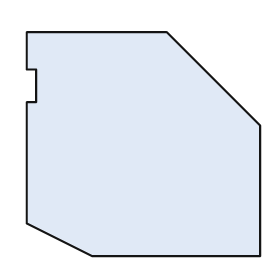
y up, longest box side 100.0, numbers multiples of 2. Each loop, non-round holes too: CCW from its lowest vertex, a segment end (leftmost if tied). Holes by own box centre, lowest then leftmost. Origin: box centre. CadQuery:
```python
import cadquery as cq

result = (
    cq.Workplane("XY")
    .moveTo(-22.0, -48.0)
    .lineTo(50.0, -48.0)
    .lineTo(50.0, 8.0)
    .lineTo(10.0, 48.0)
    .lineTo(-50.0, 48.0)
    .lineTo(-50.0, 32.0)
    .lineTo(-46.0, 32.0)
    .lineTo(-46.0, 18.0)
    .lineTo(-50.0, 18.0)
    .lineTo(-50.0, -34.0)
    .close()
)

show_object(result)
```